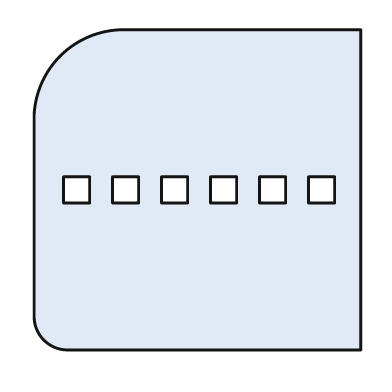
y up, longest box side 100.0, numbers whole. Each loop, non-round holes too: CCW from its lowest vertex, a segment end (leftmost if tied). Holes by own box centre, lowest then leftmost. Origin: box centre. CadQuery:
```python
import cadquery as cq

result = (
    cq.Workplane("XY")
    .moveTo(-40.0, -49.0)
    .lineTo(50.0, -49.0)
    .lineTo(50.0, 49.0)
    .lineTo(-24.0, 49.0)
    .threePointArc((-42.0, 41.0), (-50.0, 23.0))
    .lineTo(-50.0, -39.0)
    .threePointArc((-47.0, -46.0), (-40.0, -49.0))
    .close()
    .moveTo(-41.0, -4.0)
    .lineTo(-33.0, -4.0)
    .lineTo(-33.0, 4.0)
    .lineTo(-41.0, 4.0)
    .close()
    .moveTo(-26.0, -4.0)
    .lineTo(-18.0, -4.0)
    .lineTo(-18.0, 4.0)
    .lineTo(-26.0, 4.0)
    .close()
    .moveTo(-11.0, -4.0)
    .lineTo(-3.0, -4.0)
    .lineTo(-3.0, 4.0)
    .lineTo(-11.0, 4.0)
    .close()
    .moveTo(4.0, -4.0)
    .lineTo(12.0, -4.0)
    .lineTo(12.0, 4.0)
    .lineTo(4.0, 4.0)
    .close()
    .moveTo(19.0, -4.0)
    .lineTo(27.0, -4.0)
    .lineTo(27.0, 4.0)
    .lineTo(19.0, 4.0)
    .close()
    .moveTo(34.0, -4.0)
    .lineTo(42.0, -4.0)
    .lineTo(42.0, 4.0)
    .lineTo(34.0, 4.0)
    .close()
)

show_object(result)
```